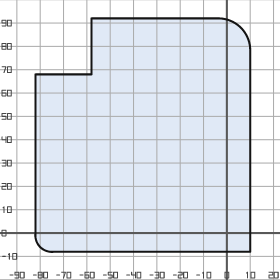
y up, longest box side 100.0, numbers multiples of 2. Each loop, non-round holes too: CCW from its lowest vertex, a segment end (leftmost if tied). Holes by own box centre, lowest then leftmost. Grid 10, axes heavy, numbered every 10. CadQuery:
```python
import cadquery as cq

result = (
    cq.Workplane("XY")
    .moveTo(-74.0, -8.0)
    .lineTo(10.0, -8.0)
    .lineTo(10.0, 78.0)
    .threePointArc((6.0, 88.0), (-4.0, 92.0))
    .lineTo(-58.0, 92.0)
    .lineTo(-58.0, 68.0)
    .lineTo(-82.0, 68.0)
    .lineTo(-82.0, 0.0)
    .threePointArc((-80.0, -6.0), (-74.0, -8.0))
    .close()
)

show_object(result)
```